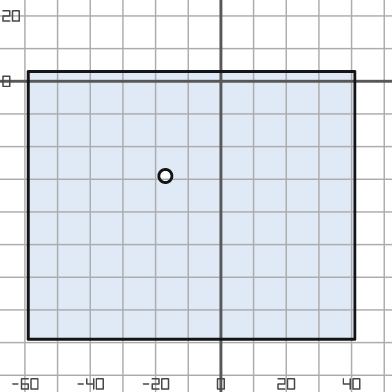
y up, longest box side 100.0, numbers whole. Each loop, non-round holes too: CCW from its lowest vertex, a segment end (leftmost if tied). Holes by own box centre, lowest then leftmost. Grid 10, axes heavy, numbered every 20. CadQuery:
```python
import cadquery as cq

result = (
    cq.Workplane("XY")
    .moveTo(-59.0, -79.0)
    .lineTo(41.0, -79.0)
    .lineTo(41.0, 3.0)
    .lineTo(-59.0, 3.0)
    .close()
    .moveTo(-17.0, -29.0)
    .circle(2.0)
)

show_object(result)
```